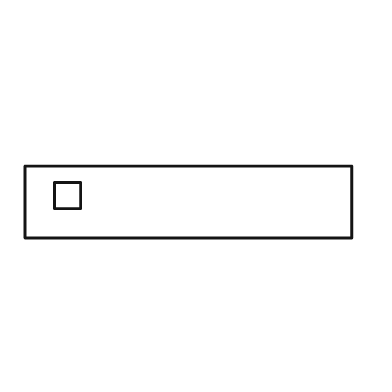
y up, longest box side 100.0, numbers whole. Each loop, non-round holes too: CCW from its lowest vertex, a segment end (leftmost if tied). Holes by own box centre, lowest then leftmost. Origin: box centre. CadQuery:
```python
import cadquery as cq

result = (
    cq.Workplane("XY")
    .moveTo(-50.0, -11.0)
    .lineTo(50.0, -11.0)
    .lineTo(50.0, 11.0)
    .lineTo(-50.0, 11.0)
    .close()
    .moveTo(-41.0, -2.0)
    .lineTo(-33.0, -2.0)
    .lineTo(-33.0, 6.0)
    .lineTo(-41.0, 6.0)
    .close()
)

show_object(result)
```